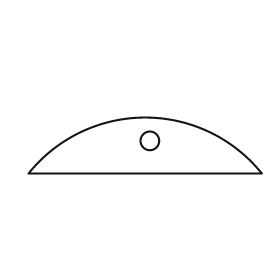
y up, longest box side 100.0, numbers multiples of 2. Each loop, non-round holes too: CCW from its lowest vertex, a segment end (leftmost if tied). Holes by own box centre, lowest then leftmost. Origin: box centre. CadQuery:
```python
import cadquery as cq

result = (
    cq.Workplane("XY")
    .moveTo(-50.0, -12.0)
    .lineTo(50.0, -12.0)
    .threePointArc((0.0, 12.0), (-50.0, -12.0))
    .close()
    .moveTo(2.0, 2.0)
    .circle(4.0)
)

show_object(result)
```